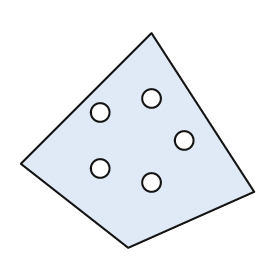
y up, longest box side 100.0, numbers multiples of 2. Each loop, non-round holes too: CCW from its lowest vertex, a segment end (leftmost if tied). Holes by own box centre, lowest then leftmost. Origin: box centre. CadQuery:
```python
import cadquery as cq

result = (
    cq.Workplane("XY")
    .moveTo(-4.0, -46.0)
    .lineTo(50.0, -22.0)
    .lineTo(6.0, 46.0)
    .lineTo(-50.0, -10.0)
    .close()
    .moveTo(6.0, -18.0)
    .circle(4.0)
    .moveTo(-16.0, -12.0)
    .circle(4.0)
    .moveTo(20.0, 0.0)
    .circle(4.0)
    .moveTo(-16.0, 12.0)
    .circle(4.0)
    .moveTo(6.0, 18.0)
    .circle(4.0)
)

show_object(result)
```